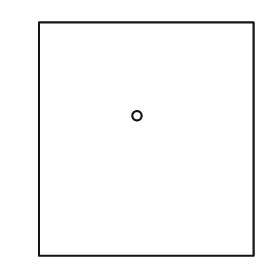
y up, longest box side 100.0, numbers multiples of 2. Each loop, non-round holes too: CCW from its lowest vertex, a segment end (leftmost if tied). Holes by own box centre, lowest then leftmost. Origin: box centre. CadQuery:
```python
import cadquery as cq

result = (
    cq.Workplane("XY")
    .moveTo(-46.0, -50.0)
    .lineTo(46.0, -50.0)
    .lineTo(46.0, 50.0)
    .lineTo(-46.0, 50.0)
    .close()
    .moveTo(-4.0, 10.0)
    .circle(2.0)
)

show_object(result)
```